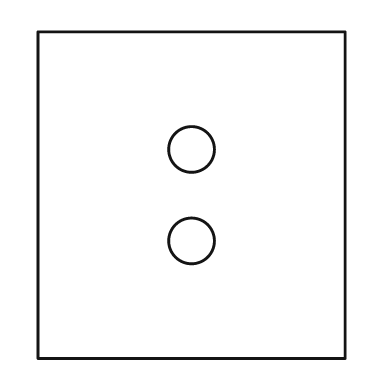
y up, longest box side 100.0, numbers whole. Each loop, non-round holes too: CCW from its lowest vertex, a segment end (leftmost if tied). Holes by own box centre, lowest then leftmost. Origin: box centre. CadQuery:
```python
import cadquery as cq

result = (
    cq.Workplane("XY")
    .moveTo(-47.0, -50.0)
    .lineTo(47.0, -50.0)
    .lineTo(47.0, 50.0)
    .lineTo(-47.0, 50.0)
    .close()
    .moveTo(0.0, -14.0)
    .circle(7.0)
    .moveTo(0.0, 14.0)
    .circle(7.0)
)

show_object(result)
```